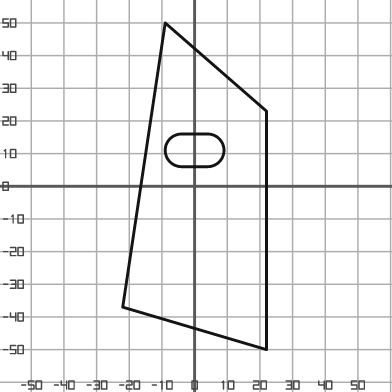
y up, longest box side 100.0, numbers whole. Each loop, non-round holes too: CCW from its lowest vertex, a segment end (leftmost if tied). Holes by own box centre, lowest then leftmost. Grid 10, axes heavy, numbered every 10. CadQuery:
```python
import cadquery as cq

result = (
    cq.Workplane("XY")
    .moveTo(22.0, -50.0)
    .lineTo(22.0, 23.0)
    .lineTo(-9.0, 50.0)
    .lineTo(-22.0, -37.0)
    .close()
    .moveTo(-4.0, 6.0)
    .lineTo(4.0, 6.0)
    .threePointArc((9.0, 11.0), (4.0, 16.0))
    .lineTo(-4.0, 16.0)
    .threePointArc((-9.0, 11.0), (-4.0, 6.0))
    .close()
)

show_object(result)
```